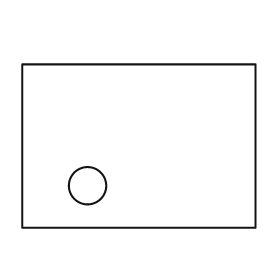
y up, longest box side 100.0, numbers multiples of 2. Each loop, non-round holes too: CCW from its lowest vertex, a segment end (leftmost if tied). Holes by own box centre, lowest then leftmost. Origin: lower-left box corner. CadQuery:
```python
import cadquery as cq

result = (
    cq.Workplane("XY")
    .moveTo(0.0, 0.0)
    .lineTo(100.0, 0.0)
    .lineTo(100.0, 70.0)
    .lineTo(0.0, 70.0)
    .close()
    .moveTo(28.0, 18.0)
    .circle(8.0)
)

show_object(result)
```